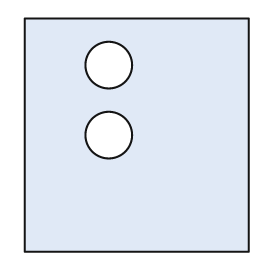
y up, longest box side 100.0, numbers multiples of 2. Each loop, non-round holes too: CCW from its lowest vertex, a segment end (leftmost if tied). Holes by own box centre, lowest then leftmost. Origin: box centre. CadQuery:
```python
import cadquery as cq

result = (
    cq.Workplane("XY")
    .moveTo(-48.0, -50.0)
    .lineTo(48.0, -50.0)
    .lineTo(48.0, 50.0)
    .lineTo(-48.0, 50.0)
    .close()
    .moveTo(-12.0, 0.0)
    .circle(10.0)
    .moveTo(-12.0, 30.0)
    .circle(10.0)
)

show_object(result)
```